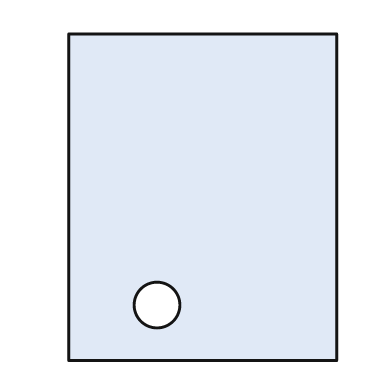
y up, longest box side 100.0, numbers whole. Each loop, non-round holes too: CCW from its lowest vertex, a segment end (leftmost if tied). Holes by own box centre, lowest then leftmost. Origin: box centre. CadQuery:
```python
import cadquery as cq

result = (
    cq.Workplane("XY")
    .moveTo(-41.0, -50.0)
    .lineTo(41.0, -50.0)
    .lineTo(41.0, 50.0)
    .lineTo(-41.0, 50.0)
    .close()
    .moveTo(-14.0, -33.0)
    .circle(7.0)
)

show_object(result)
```